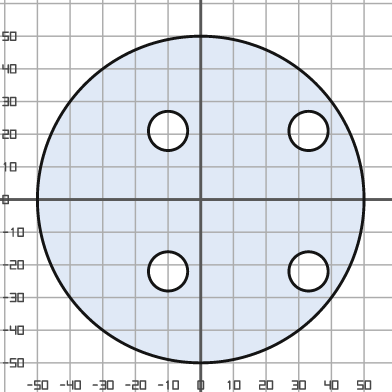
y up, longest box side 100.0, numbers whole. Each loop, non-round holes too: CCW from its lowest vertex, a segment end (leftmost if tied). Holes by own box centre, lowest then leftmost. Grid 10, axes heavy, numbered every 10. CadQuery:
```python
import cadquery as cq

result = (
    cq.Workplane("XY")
    .moveTo(0.0, 0.0)
    .circle(50.0)
    .moveTo(-10.0, -22.0)
    .circle(6.0)
    .moveTo(33.0, -22.0)
    .circle(6.0)
    .moveTo(-10.0, 21.0)
    .circle(6.0)
    .moveTo(33.0, 21.0)
    .circle(6.0)
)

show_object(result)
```